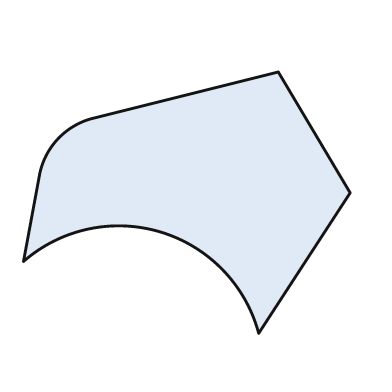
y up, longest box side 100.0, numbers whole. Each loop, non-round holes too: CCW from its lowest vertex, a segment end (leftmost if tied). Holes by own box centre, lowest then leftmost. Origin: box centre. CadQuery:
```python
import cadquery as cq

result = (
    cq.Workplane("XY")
    .moveTo(22.0, -40.0)
    .lineTo(50.0, 3.0)
    .lineTo(28.0, 40.0)
    .lineTo(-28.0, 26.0)
    .threePointArc((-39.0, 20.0), (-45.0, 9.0))
    .lineTo(-50.0, -18.0)
    .threePointArc((-8.0, -9.0), (22.0, -40.0))
    .close()
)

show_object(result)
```